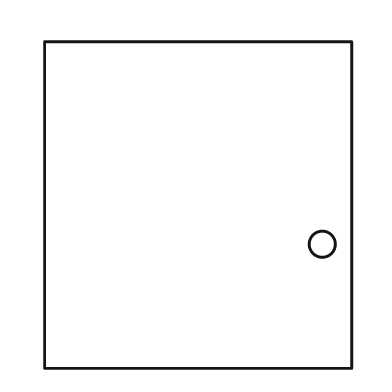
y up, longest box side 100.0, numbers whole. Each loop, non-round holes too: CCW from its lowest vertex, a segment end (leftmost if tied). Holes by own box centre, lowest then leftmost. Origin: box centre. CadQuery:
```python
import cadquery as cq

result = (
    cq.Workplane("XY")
    .moveTo(-47.0, -50.0)
    .lineTo(47.0, -50.0)
    .lineTo(47.0, 50.0)
    .lineTo(-47.0, 50.0)
    .close()
    .moveTo(38.0, -12.0)
    .circle(4.0)
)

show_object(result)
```